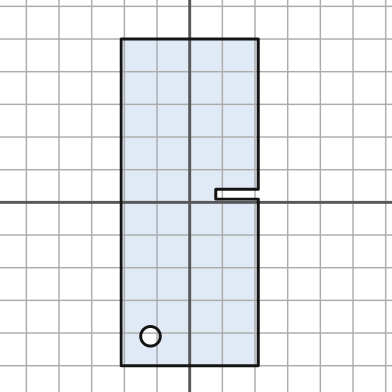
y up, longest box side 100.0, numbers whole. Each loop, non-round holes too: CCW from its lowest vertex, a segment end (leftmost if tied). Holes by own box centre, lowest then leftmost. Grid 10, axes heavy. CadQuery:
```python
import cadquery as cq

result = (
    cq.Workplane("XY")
    .moveTo(-21.0, -50.0)
    .lineTo(21.0, -50.0)
    .lineTo(21.0, 1.0)
    .lineTo(8.0, 1.0)
    .lineTo(8.0, 4.0)
    .lineTo(21.0, 4.0)
    .lineTo(21.0, 50.0)
    .lineTo(-21.0, 50.0)
    .close()
    .moveTo(-12.0, -41.0)
    .circle(3.0)
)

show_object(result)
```